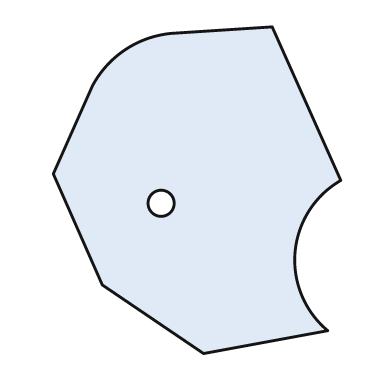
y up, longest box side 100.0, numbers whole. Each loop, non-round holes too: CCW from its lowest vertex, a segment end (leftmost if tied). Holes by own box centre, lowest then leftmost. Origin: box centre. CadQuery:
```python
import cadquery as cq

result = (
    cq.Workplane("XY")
    .moveTo(2.0, -50.0)
    .lineTo(40.0, -43.0)
    .threePointArc((30.0, -19.0), (44.0, 3.0))
    .lineTo(23.0, 50.0)
    .lineTo(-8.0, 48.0)
    .threePointArc((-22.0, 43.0), (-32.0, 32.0))
    .lineTo(-44.0, 5.0)
    .lineTo(-29.0, -29.0)
    .close()
    .moveTo(-11.0, -4.0)
    .circle(4.0)
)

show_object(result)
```